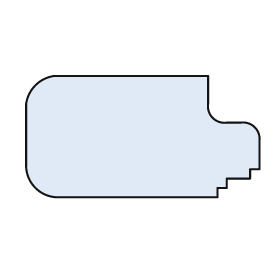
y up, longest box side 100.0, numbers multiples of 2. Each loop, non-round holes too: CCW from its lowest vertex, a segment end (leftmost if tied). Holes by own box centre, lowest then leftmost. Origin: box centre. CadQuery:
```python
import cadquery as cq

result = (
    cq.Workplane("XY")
    .moveTo(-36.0, -26.0)
    .lineTo(32.0, -26.0)
    .lineTo(32.0, -22.0)
    .lineTo(36.0, -22.0)
    .lineTo(36.0, -18.0)
    .lineTo(46.0, -18.0)
    .lineTo(46.0, -14.0)
    .lineTo(50.0, -14.0)
    .lineTo(50.0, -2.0)
    .threePointArc((48.0, 4.0), (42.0, 6.0))
    .lineTo(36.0, 6.0)
    .threePointArc((30.0, 8.0), (28.0, 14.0))
    .lineTo(28.0, 26.0)
    .lineTo(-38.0, 26.0)
    .threePointArc((-46.0, 22.0), (-50.0, 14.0))
    .lineTo(-50.0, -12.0)
    .threePointArc((-46.0, -22.0), (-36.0, -26.0))
    .close()
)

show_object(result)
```